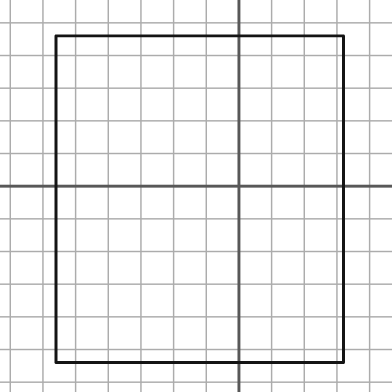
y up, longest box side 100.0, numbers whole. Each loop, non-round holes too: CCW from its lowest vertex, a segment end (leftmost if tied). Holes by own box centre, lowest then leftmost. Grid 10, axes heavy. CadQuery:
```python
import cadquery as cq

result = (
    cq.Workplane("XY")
    .moveTo(-56.0, -54.0)
    .lineTo(32.0, -54.0)
    .lineTo(32.0, 46.0)
    .lineTo(-56.0, 46.0)
    .close()
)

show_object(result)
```